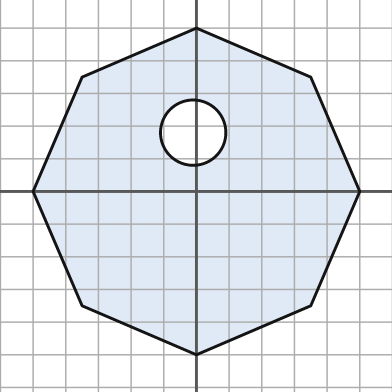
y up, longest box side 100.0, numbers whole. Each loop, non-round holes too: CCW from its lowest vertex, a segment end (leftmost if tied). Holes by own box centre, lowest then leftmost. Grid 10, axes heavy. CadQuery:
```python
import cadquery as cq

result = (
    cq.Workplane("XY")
    .moveTo(0.0, -50.0)
    .lineTo(35.0, -35.0)
    .lineTo(50.0, 0.0)
    .lineTo(35.0, 35.0)
    .lineTo(0.0, 50.0)
    .lineTo(-35.0, 35.0)
    .lineTo(-50.0, 0.0)
    .lineTo(-35.0, -35.0)
    .close()
    .moveTo(-1.0, 18.0)
    .circle(10.0)
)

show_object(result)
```